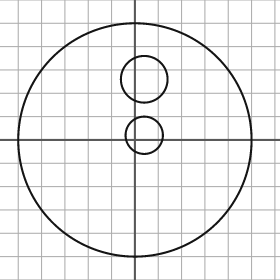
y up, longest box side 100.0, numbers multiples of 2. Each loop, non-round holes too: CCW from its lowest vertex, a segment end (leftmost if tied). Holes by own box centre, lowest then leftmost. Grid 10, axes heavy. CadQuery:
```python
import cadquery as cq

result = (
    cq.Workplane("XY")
    .moveTo(0.0, 0.0)
    .circle(50.0)
    .moveTo(4.0, 2.0)
    .circle(8.0)
    .moveTo(4.0, 26.0)
    .circle(10.0)
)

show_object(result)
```